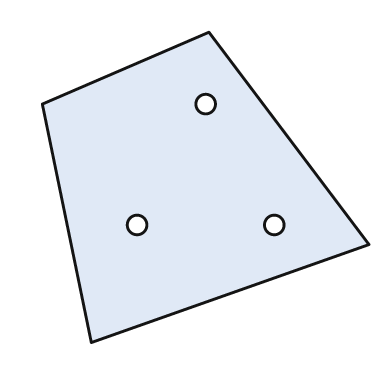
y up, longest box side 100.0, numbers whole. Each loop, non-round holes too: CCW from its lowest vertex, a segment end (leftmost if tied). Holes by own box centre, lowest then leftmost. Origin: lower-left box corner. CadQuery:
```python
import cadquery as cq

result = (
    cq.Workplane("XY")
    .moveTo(15.0, 0.0)
    .lineTo(100.0, 30.0)
    .lineTo(51.0, 95.0)
    .lineTo(0.0, 73.0)
    .close()
    .moveTo(29.0, 36.0)
    .circle(3.0)
    .moveTo(71.0, 36.0)
    .circle(3.0)
    .moveTo(50.0, 73.0)
    .circle(3.0)
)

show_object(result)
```